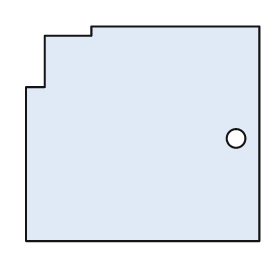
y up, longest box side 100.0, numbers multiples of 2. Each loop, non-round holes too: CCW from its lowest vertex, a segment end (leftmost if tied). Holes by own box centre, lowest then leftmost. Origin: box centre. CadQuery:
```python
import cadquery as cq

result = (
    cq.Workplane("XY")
    .moveTo(-50.0, -46.0)
    .lineTo(50.0, -46.0)
    .lineTo(50.0, 46.0)
    .lineTo(-22.0, 46.0)
    .lineTo(-22.0, 42.0)
    .lineTo(-42.0, 42.0)
    .lineTo(-42.0, 20.0)
    .lineTo(-50.0, 20.0)
    .close()
    .moveTo(40.0, -2.0)
    .circle(4.0)
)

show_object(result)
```